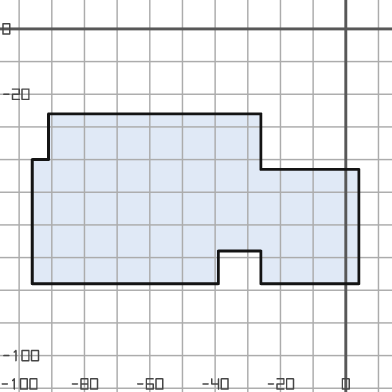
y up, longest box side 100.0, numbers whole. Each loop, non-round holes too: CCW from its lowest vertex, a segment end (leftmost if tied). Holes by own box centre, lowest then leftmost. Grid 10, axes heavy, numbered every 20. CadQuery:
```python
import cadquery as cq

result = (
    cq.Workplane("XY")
    .moveTo(-96.0, -78.0)
    .lineTo(-39.0, -78.0)
    .lineTo(-39.0, -68.0)
    .lineTo(-26.0, -68.0)
    .lineTo(-26.0, -78.0)
    .lineTo(4.0, -78.0)
    .lineTo(4.0, -43.0)
    .lineTo(-26.0, -43.0)
    .lineTo(-26.0, -26.0)
    .lineTo(-91.0, -26.0)
    .lineTo(-91.0, -40.0)
    .lineTo(-96.0, -40.0)
    .close()
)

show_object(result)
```